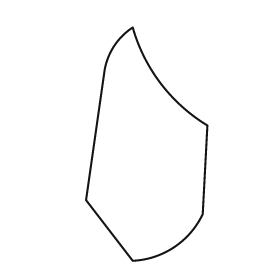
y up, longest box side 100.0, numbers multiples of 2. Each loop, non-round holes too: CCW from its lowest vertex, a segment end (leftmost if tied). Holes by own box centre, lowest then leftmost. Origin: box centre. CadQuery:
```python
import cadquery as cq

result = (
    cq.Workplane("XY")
    .moveTo(-6.0, -50.0)
    .threePointArc((12.0, -44.0), (24.0, -30.0))
    .lineTo(26.0, 8.0)
    .threePointArc((6.0, 26.0), (-6.0, 50.0))
    .threePointArc((-14.0, 42.0), (-18.0, 32.0))
    .lineTo(-26.0, -24.0)
    .close()
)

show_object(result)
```